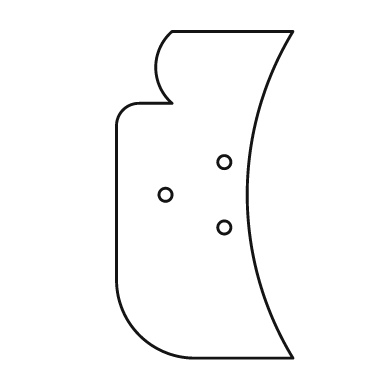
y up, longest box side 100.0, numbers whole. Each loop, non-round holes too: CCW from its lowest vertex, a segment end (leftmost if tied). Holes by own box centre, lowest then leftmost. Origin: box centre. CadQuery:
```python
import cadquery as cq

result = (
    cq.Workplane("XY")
    .moveTo(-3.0, -50.0)
    .lineTo(27.0, -50.0)
    .threePointArc((13.0, 0.0), (27.0, 50.0))
    .lineTo(-10.0, 50.0)
    .threePointArc((-15.0, 39.0), (-10.0, 28.0))
    .lineTo(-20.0, 28.0)
    .threePointArc((-25.0, 26.0), (-27.0, 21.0))
    .lineTo(-27.0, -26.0)
    .threePointArc((-20.0, -43.0), (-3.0, -50.0))
    .close()
    .moveTo(6.0, -10.0)
    .circle(2.0)
    .moveTo(-12.0, 0.0)
    .circle(2.0)
    .moveTo(6.0, 10.0)
    .circle(2.0)
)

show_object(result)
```